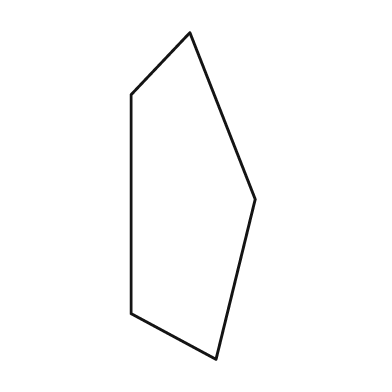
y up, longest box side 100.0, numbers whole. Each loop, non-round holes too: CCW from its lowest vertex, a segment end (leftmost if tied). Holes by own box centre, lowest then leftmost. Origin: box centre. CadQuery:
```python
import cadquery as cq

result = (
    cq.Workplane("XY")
    .moveTo(7.0, -50.0)
    .lineTo(19.0, -1.0)
    .lineTo(-1.0, 50.0)
    .lineTo(-19.0, 31.0)
    .lineTo(-19.0, -36.0)
    .close()
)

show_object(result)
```